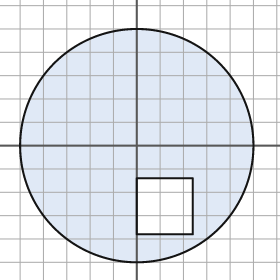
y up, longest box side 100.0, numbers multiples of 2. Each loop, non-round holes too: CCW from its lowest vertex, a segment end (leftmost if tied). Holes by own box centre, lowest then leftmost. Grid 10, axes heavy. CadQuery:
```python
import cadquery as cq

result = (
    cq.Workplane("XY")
    .moveTo(0.0, 0.0)
    .circle(50.0)
    .moveTo(0.0, -38.0)
    .lineTo(24.0, -38.0)
    .lineTo(24.0, -14.0)
    .lineTo(0.0, -14.0)
    .close()
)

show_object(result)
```